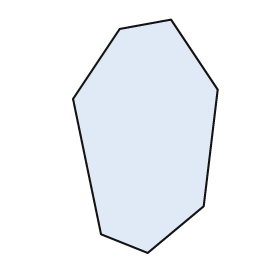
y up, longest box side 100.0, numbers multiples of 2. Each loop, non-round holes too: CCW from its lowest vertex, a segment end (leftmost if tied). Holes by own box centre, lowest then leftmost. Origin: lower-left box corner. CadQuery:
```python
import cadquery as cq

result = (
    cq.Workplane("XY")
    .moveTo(32.0, 0.0)
    .lineTo(56.0, 20.0)
    .lineTo(62.0, 70.0)
    .lineTo(42.0, 100.0)
    .lineTo(20.0, 96.0)
    .lineTo(0.0, 66.0)
    .lineTo(12.0, 8.0)
    .close()
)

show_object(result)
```